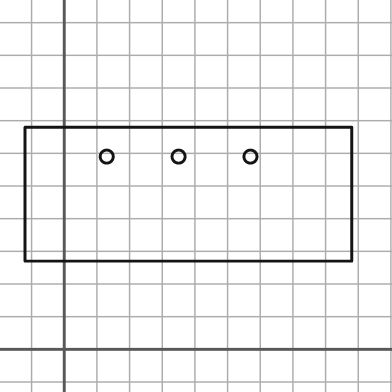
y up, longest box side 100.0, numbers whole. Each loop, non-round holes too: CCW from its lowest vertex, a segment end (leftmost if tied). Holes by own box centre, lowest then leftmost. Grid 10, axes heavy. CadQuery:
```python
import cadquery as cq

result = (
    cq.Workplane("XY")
    .moveTo(-12.0, 27.0)
    .lineTo(88.0, 27.0)
    .lineTo(88.0, 68.0)
    .lineTo(-12.0, 68.0)
    .close()
    .moveTo(13.0, 59.0)
    .circle(2.0)
    .moveTo(35.0, 59.0)
    .circle(2.0)
    .moveTo(57.0, 59.0)
    .circle(2.0)
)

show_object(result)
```